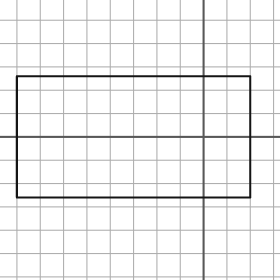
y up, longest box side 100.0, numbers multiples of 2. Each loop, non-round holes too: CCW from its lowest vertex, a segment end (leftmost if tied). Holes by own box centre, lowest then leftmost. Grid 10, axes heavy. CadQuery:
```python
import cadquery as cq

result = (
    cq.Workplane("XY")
    .moveTo(-80.0, -26.0)
    .lineTo(20.0, -26.0)
    .lineTo(20.0, 26.0)
    .lineTo(-80.0, 26.0)
    .close()
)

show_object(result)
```